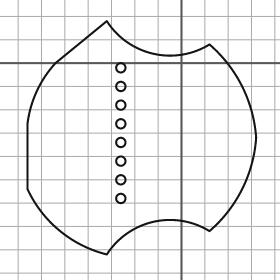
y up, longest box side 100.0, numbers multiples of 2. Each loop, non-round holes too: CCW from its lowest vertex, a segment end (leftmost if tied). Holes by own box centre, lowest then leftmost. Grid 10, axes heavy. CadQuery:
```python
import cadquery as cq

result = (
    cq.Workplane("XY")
    .moveTo(-32.0, -82.0)
    .threePointArc((-12.0, -68.0), (12.0, -72.0))
    .threePointArc((26.0, -54.0), (32.0, -32.0))
    .threePointArc((26.0, -10.0), (12.0, 8.0))
    .threePointArc((-12.0, 4.0), (-32.0, 18.0))
    .lineTo(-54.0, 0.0)
    .threePointArc((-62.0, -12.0), (-66.0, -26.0))
    .lineTo(-66.0, -54.0)
    .threePointArc((-52.0, -72.0), (-32.0, -82.0))
    .close()
    .moveTo(-26.0, -58.0)
    .circle(2.0)
    .moveTo(-26.0, -50.0)
    .circle(2.0)
    .moveTo(-26.0, -42.0)
    .circle(2.0)
    .moveTo(-26.0, -34.0)
    .circle(2.0)
    .moveTo(-26.0, -26.0)
    .circle(2.0)
    .moveTo(-26.0, -18.0)
    .circle(2.0)
    .moveTo(-26.0, -10.0)
    .circle(2.0)
    .moveTo(-26.0, -2.0)
    .circle(2.0)
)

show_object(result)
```